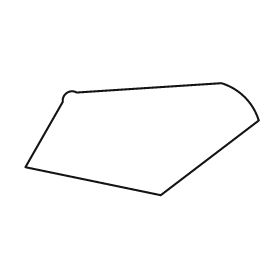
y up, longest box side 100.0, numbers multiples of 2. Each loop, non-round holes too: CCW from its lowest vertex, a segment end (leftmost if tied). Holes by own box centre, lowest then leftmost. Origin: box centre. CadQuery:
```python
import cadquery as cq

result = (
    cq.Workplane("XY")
    .moveTo(8.0, -24.0)
    .lineTo(50.0, 8.0)
    .threePointArc((44.0, 18.0), (34.0, 24.0))
    .lineTo(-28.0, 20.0)
    .threePointArc((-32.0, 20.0), (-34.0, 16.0))
    .lineTo(-50.0, -12.0)
    .close()
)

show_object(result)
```